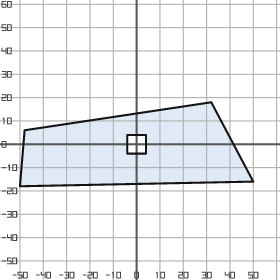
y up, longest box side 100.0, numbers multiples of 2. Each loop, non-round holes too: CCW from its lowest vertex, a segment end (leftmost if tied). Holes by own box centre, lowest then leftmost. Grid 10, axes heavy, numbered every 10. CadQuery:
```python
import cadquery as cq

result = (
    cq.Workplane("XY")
    .moveTo(-50.0, -18.0)
    .lineTo(50.0, -16.0)
    .lineTo(32.0, 18.0)
    .lineTo(-48.0, 6.0)
    .close()
    .moveTo(-4.0, -4.0)
    .lineTo(4.0, -4.0)
    .lineTo(4.0, 4.0)
    .lineTo(-4.0, 4.0)
    .close()
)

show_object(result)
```